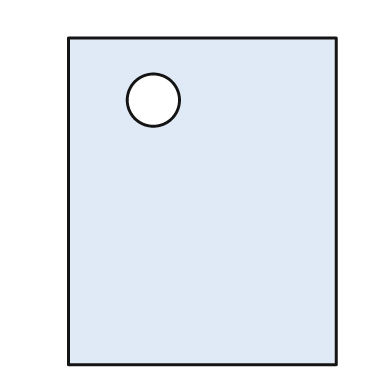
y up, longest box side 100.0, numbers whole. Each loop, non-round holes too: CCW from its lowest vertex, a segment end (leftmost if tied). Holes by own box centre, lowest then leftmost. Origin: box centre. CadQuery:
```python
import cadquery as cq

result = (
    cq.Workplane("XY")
    .moveTo(-41.0, -50.0)
    .lineTo(41.0, -50.0)
    .lineTo(41.0, 50.0)
    .lineTo(-41.0, 50.0)
    .close()
    .moveTo(-15.0, 31.0)
    .circle(8.0)
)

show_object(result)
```